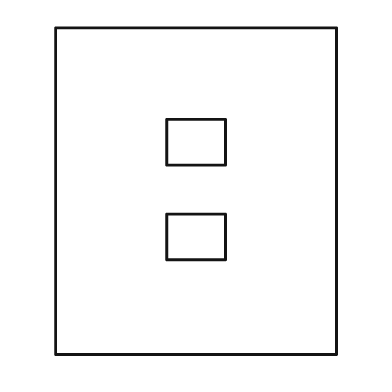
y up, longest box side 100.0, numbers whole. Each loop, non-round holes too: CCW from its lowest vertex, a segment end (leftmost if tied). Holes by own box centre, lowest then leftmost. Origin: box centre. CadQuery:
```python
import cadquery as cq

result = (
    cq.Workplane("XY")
    .moveTo(-43.0, -50.0)
    .lineTo(43.0, -50.0)
    .lineTo(43.0, 50.0)
    .lineTo(-43.0, 50.0)
    .close()
    .moveTo(-9.0, -21.0)
    .lineTo(9.0, -21.0)
    .lineTo(9.0, -7.0)
    .lineTo(-9.0, -7.0)
    .close()
    .moveTo(-9.0, 8.0)
    .lineTo(9.0, 8.0)
    .lineTo(9.0, 22.0)
    .lineTo(-9.0, 22.0)
    .close()
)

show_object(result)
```